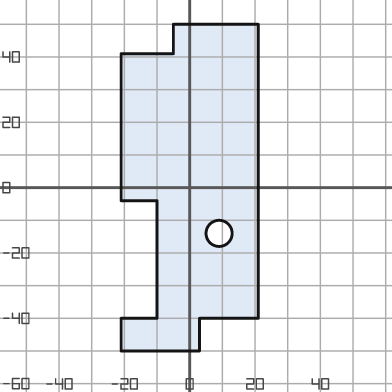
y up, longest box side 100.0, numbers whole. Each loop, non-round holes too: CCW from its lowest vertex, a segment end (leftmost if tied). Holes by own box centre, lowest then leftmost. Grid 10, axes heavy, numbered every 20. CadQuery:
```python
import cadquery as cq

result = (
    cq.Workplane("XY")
    .moveTo(-21.0, -50.0)
    .lineTo(3.0, -50.0)
    .lineTo(3.0, -40.0)
    .lineTo(21.0, -40.0)
    .lineTo(21.0, 50.0)
    .lineTo(-5.0, 50.0)
    .lineTo(-5.0, 41.0)
    .lineTo(-21.0, 41.0)
    .lineTo(-21.0, -4.0)
    .lineTo(-10.0, -4.0)
    .lineTo(-10.0, -40.0)
    .lineTo(-21.0, -40.0)
    .close()
    .moveTo(9.0, -14.0)
    .circle(4.0)
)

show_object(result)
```